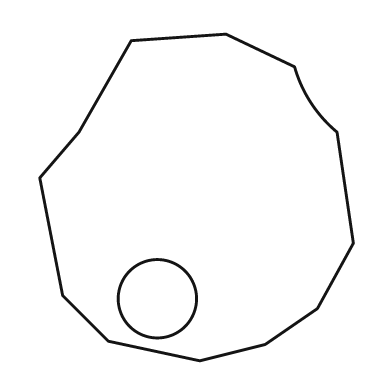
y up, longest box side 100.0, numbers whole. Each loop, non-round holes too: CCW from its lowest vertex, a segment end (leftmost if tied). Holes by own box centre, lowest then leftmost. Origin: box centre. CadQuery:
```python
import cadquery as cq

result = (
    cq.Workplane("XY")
    .moveTo(1.0, -50.0)
    .lineTo(21.0, -45.0)
    .lineTo(37.0, -34.0)
    .lineTo(48.0, -14.0)
    .lineTo(43.0, 20.0)
    .threePointArc((35.0, 29.0), (30.0, 40.0))
    .lineTo(9.0, 50.0)
    .lineTo(-20.0, 48.0)
    .lineTo(-36.0, 20.0)
    .lineTo(-48.0, 6.0)
    .lineTo(-41.0, -30.0)
    .lineTo(-27.0, -44.0)
    .close()
    .moveTo(-12.0, -31.0)
    .circle(12.0)
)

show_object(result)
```